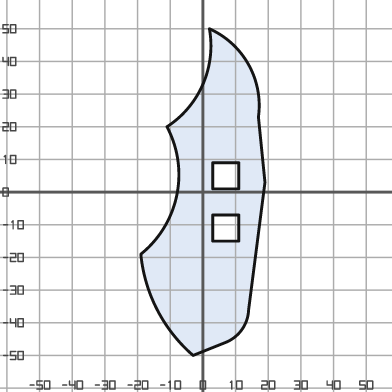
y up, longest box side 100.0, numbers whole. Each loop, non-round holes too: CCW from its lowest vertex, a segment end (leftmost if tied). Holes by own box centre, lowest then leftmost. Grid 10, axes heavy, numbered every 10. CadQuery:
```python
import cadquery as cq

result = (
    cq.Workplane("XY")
    .moveTo(-3.0, -50.0)
    .lineTo(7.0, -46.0)
    .threePointArc((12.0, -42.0), (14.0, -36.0))
    .lineTo(19.0, 3.0)
    .lineTo(17.0, 23.0)
    .threePointArc((14.0, 39.0), (2.0, 50.0))
    .threePointArc((0.0, 33.0), (-11.0, 20.0))
    .threePointArc((-8.0, -1.0), (-19.0, -19.0))
    .threePointArc((-14.0, -36.0), (-3.0, -50.0))
    .close()
    .moveTo(3.0, -15.0)
    .lineTo(11.0, -15.0)
    .lineTo(11.0, -7.0)
    .lineTo(3.0, -7.0)
    .close()
    .moveTo(3.0, 1.0)
    .lineTo(11.0, 1.0)
    .lineTo(11.0, 9.0)
    .lineTo(3.0, 9.0)
    .close()
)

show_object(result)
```